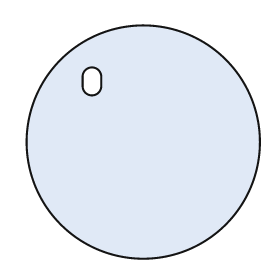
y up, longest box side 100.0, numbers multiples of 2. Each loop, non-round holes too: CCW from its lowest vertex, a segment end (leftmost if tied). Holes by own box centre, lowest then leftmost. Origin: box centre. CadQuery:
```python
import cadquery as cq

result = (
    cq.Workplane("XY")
    .moveTo(0.0, 0.0)
    .circle(50.0)
    .moveTo(-26.0, 24.0)
    .threePointArc((-22.0, 20.0), (-18.0, 24.0))
    .lineTo(-18.0, 28.0)
    .threePointArc((-22.0, 32.0), (-26.0, 28.0))
    .close()
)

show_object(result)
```